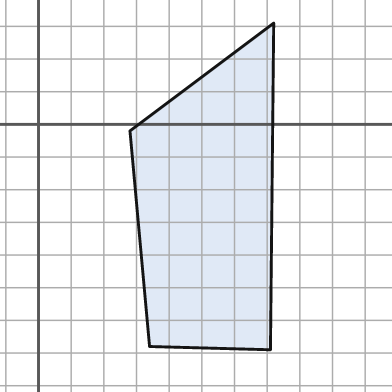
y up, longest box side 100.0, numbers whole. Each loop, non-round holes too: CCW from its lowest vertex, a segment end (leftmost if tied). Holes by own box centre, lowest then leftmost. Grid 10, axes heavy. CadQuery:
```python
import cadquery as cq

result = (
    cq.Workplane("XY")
    .moveTo(71.0, -69.0)
    .lineTo(72.0, 31.0)
    .lineTo(28.0, -2.0)
    .lineTo(34.0, -68.0)
    .close()
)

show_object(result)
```